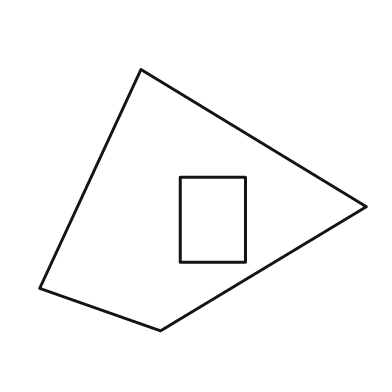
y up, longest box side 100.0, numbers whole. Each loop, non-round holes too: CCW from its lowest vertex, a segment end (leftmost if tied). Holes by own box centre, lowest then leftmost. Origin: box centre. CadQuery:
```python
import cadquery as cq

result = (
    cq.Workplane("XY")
    .moveTo(-13.0, -40.0)
    .lineTo(50.0, -2.0)
    .lineTo(-19.0, 40.0)
    .lineTo(-50.0, -27.0)
    .close()
    .moveTo(-7.0, -19.0)
    .lineTo(13.0, -19.0)
    .lineTo(13.0, 7.0)
    .lineTo(-7.0, 7.0)
    .close()
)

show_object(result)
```